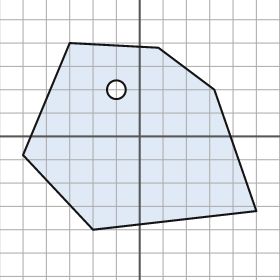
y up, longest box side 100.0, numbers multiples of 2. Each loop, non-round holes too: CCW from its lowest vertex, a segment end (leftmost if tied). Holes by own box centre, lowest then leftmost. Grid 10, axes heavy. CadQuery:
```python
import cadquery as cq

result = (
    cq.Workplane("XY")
    .moveTo(-20.0, -40.0)
    .lineTo(50.0, -32.0)
    .lineTo(32.0, 20.0)
    .lineTo(8.0, 38.0)
    .lineTo(-30.0, 40.0)
    .lineTo(-50.0, -8.0)
    .close()
    .moveTo(-10.0, 20.0)
    .circle(4.0)
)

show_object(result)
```